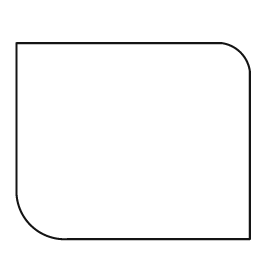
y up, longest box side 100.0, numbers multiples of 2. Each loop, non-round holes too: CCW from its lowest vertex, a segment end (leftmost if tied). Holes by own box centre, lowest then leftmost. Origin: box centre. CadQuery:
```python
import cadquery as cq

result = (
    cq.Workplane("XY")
    .moveTo(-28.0, -42.0)
    .lineTo(50.0, -42.0)
    .lineTo(50.0, 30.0)
    .threePointArc((46.0, 38.0), (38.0, 42.0))
    .lineTo(-50.0, 42.0)
    .lineTo(-50.0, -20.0)
    .threePointArc((-44.0, -36.0), (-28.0, -42.0))
    .close()
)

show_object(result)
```